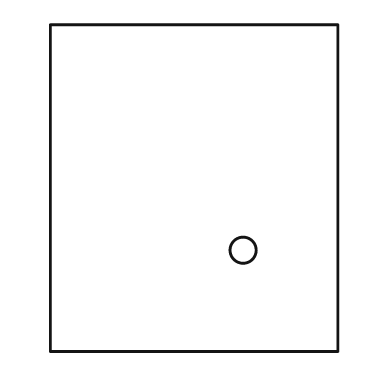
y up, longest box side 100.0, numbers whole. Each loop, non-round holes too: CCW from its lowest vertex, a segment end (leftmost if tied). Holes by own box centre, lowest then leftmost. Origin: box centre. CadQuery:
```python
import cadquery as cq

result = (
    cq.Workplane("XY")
    .moveTo(-44.0, -50.0)
    .lineTo(44.0, -50.0)
    .lineTo(44.0, 50.0)
    .lineTo(-44.0, 50.0)
    .close()
    .moveTo(15.0, -19.0)
    .circle(4.0)
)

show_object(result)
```